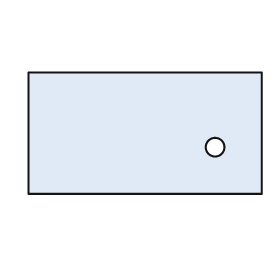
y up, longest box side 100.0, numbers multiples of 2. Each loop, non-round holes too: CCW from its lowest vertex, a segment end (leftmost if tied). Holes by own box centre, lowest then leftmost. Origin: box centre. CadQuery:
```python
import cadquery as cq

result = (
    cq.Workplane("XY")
    .moveTo(-50.0, -26.0)
    .lineTo(50.0, -26.0)
    .lineTo(50.0, 26.0)
    .lineTo(-50.0, 26.0)
    .close()
    .moveTo(30.0, -6.0)
    .circle(4.0)
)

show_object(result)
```